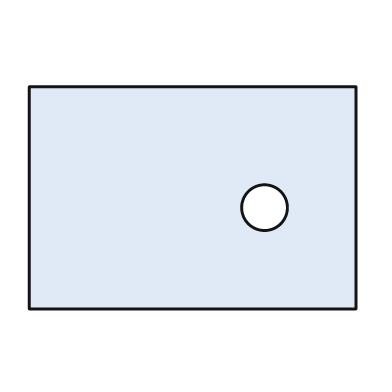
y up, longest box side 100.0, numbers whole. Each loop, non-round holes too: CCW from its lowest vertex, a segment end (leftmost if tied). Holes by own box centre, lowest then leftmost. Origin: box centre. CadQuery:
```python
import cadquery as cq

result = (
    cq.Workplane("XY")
    .moveTo(-50.0, -34.0)
    .lineTo(50.0, -34.0)
    .lineTo(50.0, 34.0)
    .lineTo(-50.0, 34.0)
    .close()
    .moveTo(22.0, -3.0)
    .circle(7.0)
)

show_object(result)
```